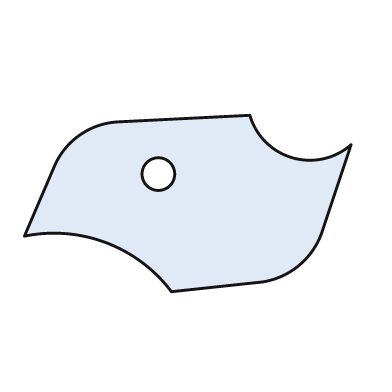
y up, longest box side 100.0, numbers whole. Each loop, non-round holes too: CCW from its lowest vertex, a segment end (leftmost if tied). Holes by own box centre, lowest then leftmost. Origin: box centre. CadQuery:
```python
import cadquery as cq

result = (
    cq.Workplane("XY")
    .moveTo(-5.0, -27.0)
    .lineTo(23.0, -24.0)
    .threePointArc((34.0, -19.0), (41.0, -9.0))
    .lineTo(50.0, 18.0)
    .threePointArc((32.0, 14.0), (19.0, 27.0))
    .lineTo(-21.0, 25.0)
    .threePointArc((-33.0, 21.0), (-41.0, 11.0))
    .lineTo(-50.0, -10.0)
    .threePointArc((-25.0, -12.0), (-5.0, -27.0))
    .close()
    .moveTo(-9.0, 9.0)
    .circle(5.0)
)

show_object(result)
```